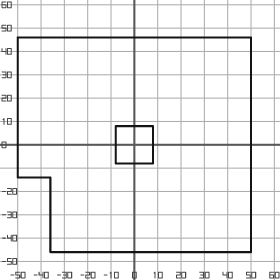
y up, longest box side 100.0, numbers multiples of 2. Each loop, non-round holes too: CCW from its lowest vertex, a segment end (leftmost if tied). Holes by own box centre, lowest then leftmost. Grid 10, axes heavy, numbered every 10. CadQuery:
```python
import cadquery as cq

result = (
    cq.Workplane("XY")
    .moveTo(-36.0, -46.0)
    .lineTo(50.0, -46.0)
    .lineTo(50.0, 46.0)
    .lineTo(-50.0, 46.0)
    .lineTo(-50.0, -14.0)
    .lineTo(-36.0, -14.0)
    .close()
    .moveTo(-8.0, -8.0)
    .lineTo(8.0, -8.0)
    .lineTo(8.0, 8.0)
    .lineTo(-8.0, 8.0)
    .close()
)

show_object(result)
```